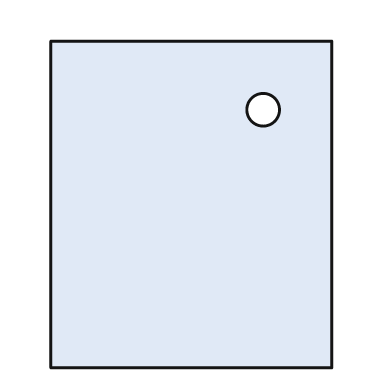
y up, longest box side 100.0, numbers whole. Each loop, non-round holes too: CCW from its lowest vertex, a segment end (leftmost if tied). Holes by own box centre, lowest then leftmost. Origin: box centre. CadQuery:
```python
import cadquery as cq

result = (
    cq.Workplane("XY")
    .moveTo(-43.0, -50.0)
    .lineTo(43.0, -50.0)
    .lineTo(43.0, 50.0)
    .lineTo(-43.0, 50.0)
    .close()
    .moveTo(22.0, 29.0)
    .circle(5.0)
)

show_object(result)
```